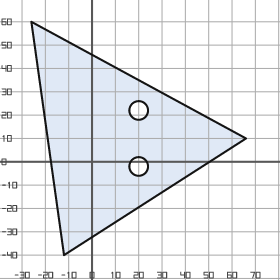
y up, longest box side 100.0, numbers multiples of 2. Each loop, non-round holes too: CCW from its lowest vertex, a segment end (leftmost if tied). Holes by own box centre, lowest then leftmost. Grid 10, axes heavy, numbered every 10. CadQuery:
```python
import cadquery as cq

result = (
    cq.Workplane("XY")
    .moveTo(-12.0, -40.0)
    .lineTo(66.0, 10.0)
    .lineTo(-26.0, 60.0)
    .close()
    .moveTo(20.0, -2.0)
    .circle(4.0)
    .moveTo(20.0, 22.0)
    .circle(4.0)
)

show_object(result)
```